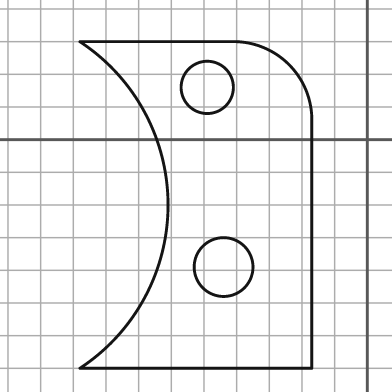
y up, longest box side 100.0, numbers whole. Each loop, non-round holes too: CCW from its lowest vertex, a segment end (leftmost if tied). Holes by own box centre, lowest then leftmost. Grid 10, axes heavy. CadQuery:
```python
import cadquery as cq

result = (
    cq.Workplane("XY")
    .moveTo(-88.0, -70.0)
    .lineTo(-17.0, -70.0)
    .lineTo(-17.0, 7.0)
    .threePointArc((-24.0, 23.0), (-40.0, 30.0))
    .lineTo(-88.0, 30.0)
    .threePointArc((-61.0, -20.0), (-88.0, -70.0))
    .close()
    .moveTo(-44.0, -39.0)
    .circle(9.0)
    .moveTo(-49.0, 16.0)
    .circle(8.0)
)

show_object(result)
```